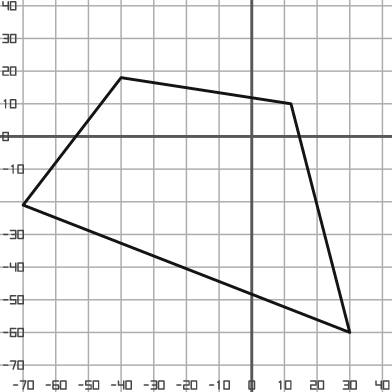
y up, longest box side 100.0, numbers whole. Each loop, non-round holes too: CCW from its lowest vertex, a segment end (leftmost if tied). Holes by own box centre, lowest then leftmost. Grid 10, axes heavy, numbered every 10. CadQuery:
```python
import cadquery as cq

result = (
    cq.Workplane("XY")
    .moveTo(30.0, -60.0)
    .lineTo(12.0, 10.0)
    .lineTo(-40.0, 18.0)
    .lineTo(-70.0, -21.0)
    .close()
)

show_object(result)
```